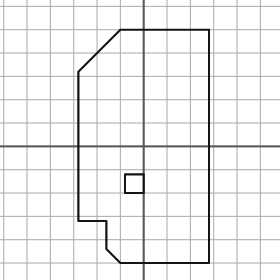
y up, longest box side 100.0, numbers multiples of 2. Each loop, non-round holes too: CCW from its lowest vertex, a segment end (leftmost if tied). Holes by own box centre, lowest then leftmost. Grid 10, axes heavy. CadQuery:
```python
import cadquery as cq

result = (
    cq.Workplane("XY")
    .moveTo(-10.0, -50.0)
    .lineTo(28.0, -50.0)
    .lineTo(28.0, 50.0)
    .lineTo(-10.0, 50.0)
    .lineTo(-28.0, 32.0)
    .lineTo(-28.0, -32.0)
    .lineTo(-16.0, -32.0)
    .lineTo(-16.0, -44.0)
    .close()
    .moveTo(-8.0, -20.0)
    .lineTo(0.0, -20.0)
    .lineTo(0.0, -12.0)
    .lineTo(-8.0, -12.0)
    .close()
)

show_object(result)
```